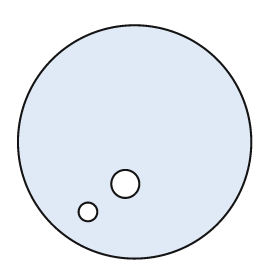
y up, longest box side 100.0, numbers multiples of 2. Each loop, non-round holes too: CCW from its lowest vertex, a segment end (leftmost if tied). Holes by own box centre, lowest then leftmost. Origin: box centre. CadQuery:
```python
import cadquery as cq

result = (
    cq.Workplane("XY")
    .moveTo(0.0, 0.0)
    .circle(50.0)
    .moveTo(-20.0, -30.0)
    .circle(4.0)
    .moveTo(-4.0, -18.0)
    .circle(6.0)
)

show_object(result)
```